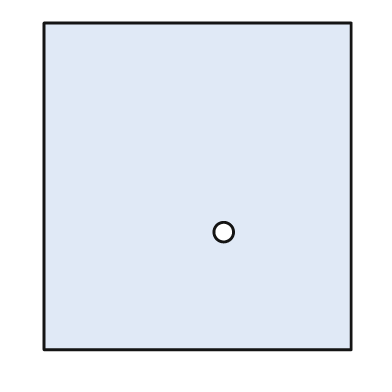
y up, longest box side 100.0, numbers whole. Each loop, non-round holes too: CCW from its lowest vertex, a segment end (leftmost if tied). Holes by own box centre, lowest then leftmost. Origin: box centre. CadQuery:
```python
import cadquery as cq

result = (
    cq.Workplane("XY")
    .moveTo(-47.0, -50.0)
    .lineTo(47.0, -50.0)
    .lineTo(47.0, 50.0)
    .lineTo(-47.0, 50.0)
    .close()
    .moveTo(8.0, -14.0)
    .circle(3.0)
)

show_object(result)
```